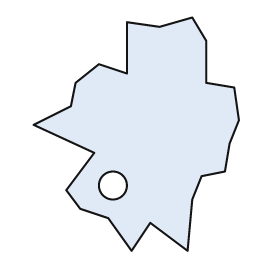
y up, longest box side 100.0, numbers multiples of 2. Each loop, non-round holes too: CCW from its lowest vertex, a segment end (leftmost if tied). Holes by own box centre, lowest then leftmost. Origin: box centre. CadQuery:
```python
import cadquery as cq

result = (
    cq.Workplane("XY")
    .moveTo(-2.0, -50.0)
    .lineTo(6.0, -38.0)
    .lineTo(22.0, -50.0)
    .lineTo(24.0, -28.0)
    .lineTo(28.0, -18.0)
    .lineTo(38.0, -16.0)
    .lineTo(40.0, -4.0)
    .lineTo(44.0, 6.0)
    .lineTo(42.0, 20.0)
    .lineTo(30.0, 22.0)
    .lineTo(30.0, 40.0)
    .lineTo(24.0, 50.0)
    .lineTo(10.0, 46.0)
    .lineTo(-4.0, 48.0)
    .lineTo(-4.0, 26.0)
    .lineTo(-16.0, 30.0)
    .lineTo(-26.0, 22.0)
    .lineTo(-28.0, 12.0)
    .lineTo(-44.0, 4.0)
    .lineTo(-18.0, -8.0)
    .lineTo(-30.0, -24.0)
    .lineTo(-24.0, -32.0)
    .lineTo(-12.0, -36.0)
    .close()
    .moveTo(-10.0, -22.0)
    .circle(6.0)
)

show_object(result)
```